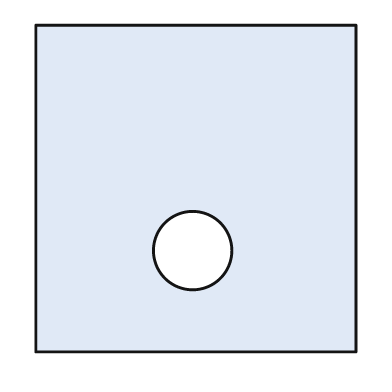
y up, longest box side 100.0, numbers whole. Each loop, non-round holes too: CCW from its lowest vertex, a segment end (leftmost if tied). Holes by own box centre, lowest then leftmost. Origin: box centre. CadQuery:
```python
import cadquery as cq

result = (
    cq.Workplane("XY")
    .moveTo(-49.0, -50.0)
    .lineTo(49.0, -50.0)
    .lineTo(49.0, 50.0)
    .lineTo(-49.0, 50.0)
    .close()
    .moveTo(-1.0, -19.0)
    .circle(12.0)
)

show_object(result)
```